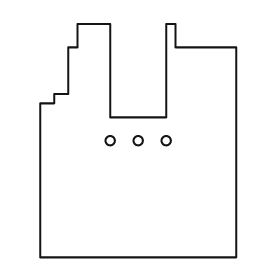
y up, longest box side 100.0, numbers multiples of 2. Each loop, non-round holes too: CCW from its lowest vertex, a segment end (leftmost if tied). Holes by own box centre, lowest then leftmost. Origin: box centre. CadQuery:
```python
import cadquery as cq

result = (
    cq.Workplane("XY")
    .moveTo(-42.0, -50.0)
    .lineTo(42.0, -50.0)
    .lineTo(42.0, 40.0)
    .lineTo(16.0, 40.0)
    .lineTo(16.0, 50.0)
    .lineTo(12.0, 50.0)
    .lineTo(12.0, 10.0)
    .lineTo(-12.0, 10.0)
    .lineTo(-12.0, 50.0)
    .lineTo(-26.0, 50.0)
    .lineTo(-26.0, 40.0)
    .lineTo(-30.0, 40.0)
    .lineTo(-30.0, 20.0)
    .lineTo(-36.0, 20.0)
    .lineTo(-36.0, 16.0)
    .lineTo(-42.0, 16.0)
    .close()
    .moveTo(-12.0, 0.0)
    .circle(2.0)
    .moveTo(0.0, 0.0)
    .circle(2.0)
    .moveTo(12.0, 0.0)
    .circle(2.0)
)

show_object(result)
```